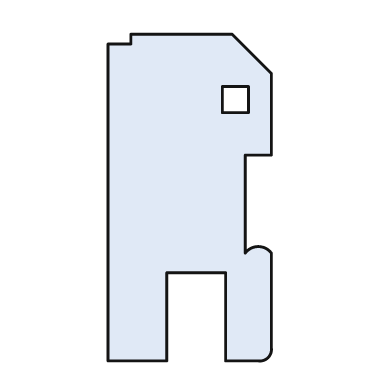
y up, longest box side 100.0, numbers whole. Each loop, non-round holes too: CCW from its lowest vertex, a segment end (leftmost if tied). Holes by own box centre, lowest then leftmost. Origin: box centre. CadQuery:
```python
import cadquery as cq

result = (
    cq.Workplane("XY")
    .moveTo(-25.0, -50.0)
    .lineTo(-7.0, -50.0)
    .lineTo(-7.0, -23.0)
    .lineTo(11.0, -23.0)
    .lineTo(11.0, -50.0)
    .lineTo(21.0, -50.0)
    .threePointArc((24.0, -49.0), (25.0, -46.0))
    .lineTo(25.0, -17.0)
    .threePointArc((21.0, -15.0), (17.0, -17.0))
    .lineTo(17.0, 13.0)
    .lineTo(25.0, 13.0)
    .lineTo(25.0, 38.0)
    .lineTo(13.0, 50.0)
    .lineTo(-18.0, 50.0)
    .lineTo(-18.0, 47.0)
    .lineTo(-25.0, 47.0)
    .close()
    .moveTo(10.0, 26.0)
    .lineTo(18.0, 26.0)
    .lineTo(18.0, 34.0)
    .lineTo(10.0, 34.0)
    .close()
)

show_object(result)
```